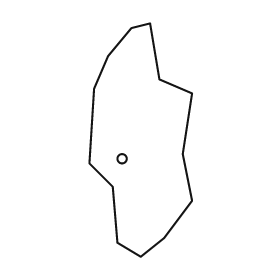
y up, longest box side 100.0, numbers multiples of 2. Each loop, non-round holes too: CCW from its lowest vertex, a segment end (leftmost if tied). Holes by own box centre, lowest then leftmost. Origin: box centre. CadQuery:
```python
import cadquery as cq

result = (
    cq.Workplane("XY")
    .moveTo(0.0, -50.0)
    .lineTo(10.0, -42.0)
    .lineTo(22.0, -26.0)
    .lineTo(18.0, -6.0)
    .lineTo(22.0, 20.0)
    .lineTo(8.0, 26.0)
    .lineTo(4.0, 50.0)
    .lineTo(-4.0, 48.0)
    .lineTo(-14.0, 36.0)
    .lineTo(-20.0, 22.0)
    .lineTo(-22.0, -10.0)
    .lineTo(-12.0, -20.0)
    .lineTo(-10.0, -44.0)
    .close()
    .moveTo(-8.0, -8.0)
    .circle(2.0)
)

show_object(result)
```